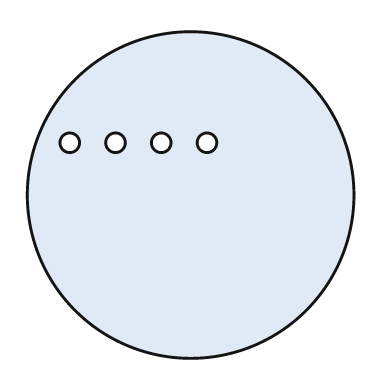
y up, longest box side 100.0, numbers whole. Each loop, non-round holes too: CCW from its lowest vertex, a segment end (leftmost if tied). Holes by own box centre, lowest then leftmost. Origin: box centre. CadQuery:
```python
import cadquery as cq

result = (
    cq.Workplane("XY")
    .moveTo(0.0, 0.0)
    .circle(50.0)
    .moveTo(-37.0, 16.0)
    .circle(3.0)
    .moveTo(-23.0, 16.0)
    .circle(3.0)
    .moveTo(-9.0, 16.0)
    .circle(3.0)
    .moveTo(5.0, 16.0)
    .circle(3.0)
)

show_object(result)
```